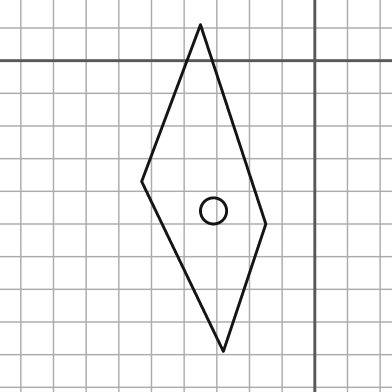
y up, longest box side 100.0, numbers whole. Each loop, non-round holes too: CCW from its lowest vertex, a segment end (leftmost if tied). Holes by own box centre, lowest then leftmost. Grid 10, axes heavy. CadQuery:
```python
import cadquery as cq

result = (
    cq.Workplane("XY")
    .moveTo(-28.0, -89.0)
    .lineTo(-15.0, -50.0)
    .lineTo(-35.0, 11.0)
    .lineTo(-53.0, -37.0)
    .close()
    .moveTo(-31.0, -46.0)
    .circle(4.0)
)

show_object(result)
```